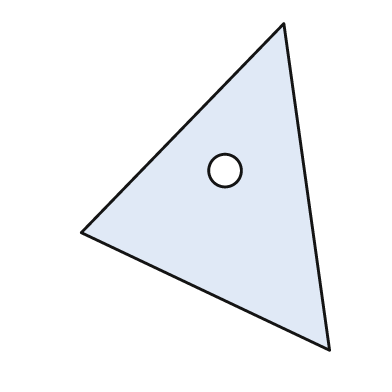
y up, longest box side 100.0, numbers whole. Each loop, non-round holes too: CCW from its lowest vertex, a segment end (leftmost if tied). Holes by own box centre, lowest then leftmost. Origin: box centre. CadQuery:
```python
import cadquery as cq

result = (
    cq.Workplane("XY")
    .moveTo(38.0, -50.0)
    .lineTo(24.0, 50.0)
    .lineTo(-38.0, -14.0)
    .close()
    .moveTo(6.0, 5.0)
    .circle(5.0)
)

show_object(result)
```